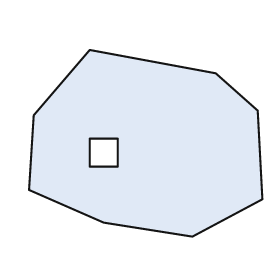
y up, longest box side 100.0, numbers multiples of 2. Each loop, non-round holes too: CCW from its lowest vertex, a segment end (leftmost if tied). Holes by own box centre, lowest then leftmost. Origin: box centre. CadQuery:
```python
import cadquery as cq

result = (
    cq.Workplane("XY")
    .moveTo(20.0, -40.0)
    .lineTo(50.0, -24.0)
    .lineTo(48.0, 14.0)
    .lineTo(30.0, 30.0)
    .lineTo(-24.0, 40.0)
    .lineTo(-48.0, 12.0)
    .lineTo(-50.0, -20.0)
    .lineTo(-18.0, -34.0)
    .close()
    .moveTo(-24.0, -10.0)
    .lineTo(-12.0, -10.0)
    .lineTo(-12.0, 2.0)
    .lineTo(-24.0, 2.0)
    .close()
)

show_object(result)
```